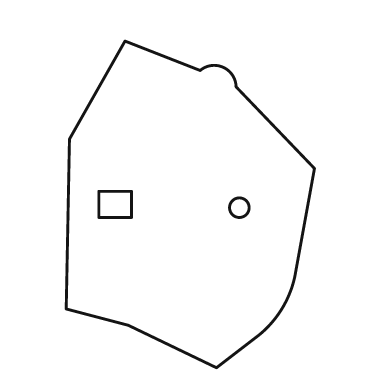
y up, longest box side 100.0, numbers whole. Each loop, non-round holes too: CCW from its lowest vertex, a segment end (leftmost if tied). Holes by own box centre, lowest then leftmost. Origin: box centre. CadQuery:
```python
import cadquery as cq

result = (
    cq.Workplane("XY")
    .moveTo(8.0, -50.0)
    .lineTo(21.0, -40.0)
    .threePointArc((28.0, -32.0), (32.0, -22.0))
    .lineTo(38.0, 11.0)
    .lineTo(14.0, 36.0)
    .threePointArc((10.0, 42.0), (3.0, 41.0))
    .lineTo(-20.0, 50.0)
    .lineTo(-37.0, 20.0)
    .lineTo(-38.0, -32.0)
    .lineTo(-19.0, -37.0)
    .close()
    .moveTo(15.0, -1.0)
    .circle(3.0)
    .moveTo(-28.0, -4.0)
    .lineTo(-18.0, -4.0)
    .lineTo(-18.0, 4.0)
    .lineTo(-28.0, 4.0)
    .close()
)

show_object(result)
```